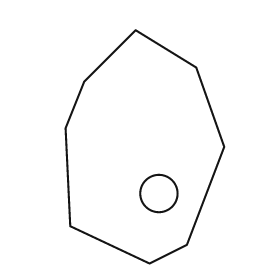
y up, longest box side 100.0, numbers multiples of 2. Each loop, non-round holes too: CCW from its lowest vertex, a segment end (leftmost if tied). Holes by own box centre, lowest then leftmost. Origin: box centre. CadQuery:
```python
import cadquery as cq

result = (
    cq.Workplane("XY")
    .moveTo(2.0, -50.0)
    .lineTo(18.0, -42.0)
    .lineTo(34.0, 0.0)
    .lineTo(22.0, 34.0)
    .lineTo(-4.0, 50.0)
    .lineTo(-26.0, 28.0)
    .lineTo(-34.0, 8.0)
    .lineTo(-32.0, -34.0)
    .close()
    .moveTo(6.0, -20.0)
    .circle(8.0)
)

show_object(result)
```